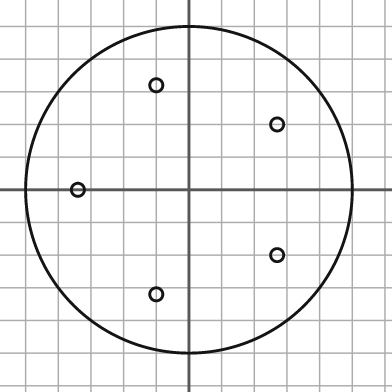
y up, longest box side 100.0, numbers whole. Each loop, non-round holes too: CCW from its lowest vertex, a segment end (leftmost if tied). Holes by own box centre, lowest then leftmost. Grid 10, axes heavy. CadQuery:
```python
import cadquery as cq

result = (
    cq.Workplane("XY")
    .moveTo(0.0, 0.0)
    .circle(50.0)
    .moveTo(-10.0, -32.0)
    .circle(2.0)
    .moveTo(27.0, -20.0)
    .circle(2.0)
    .moveTo(-34.0, 0.0)
    .circle(2.0)
    .moveTo(27.0, 20.0)
    .circle(2.0)
    .moveTo(-10.0, 32.0)
    .circle(2.0)
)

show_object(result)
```